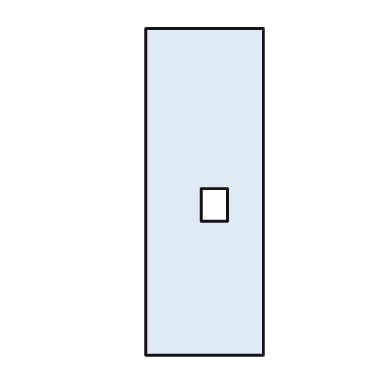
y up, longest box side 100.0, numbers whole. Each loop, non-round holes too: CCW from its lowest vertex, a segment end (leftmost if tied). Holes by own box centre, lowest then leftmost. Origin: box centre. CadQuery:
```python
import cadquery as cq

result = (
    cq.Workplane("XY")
    .moveTo(-18.0, -50.0)
    .lineTo(18.0, -50.0)
    .lineTo(18.0, 50.0)
    .lineTo(-18.0, 50.0)
    .close()
    .moveTo(-1.0, -9.0)
    .lineTo(7.0, -9.0)
    .lineTo(7.0, 1.0)
    .lineTo(-1.0, 1.0)
    .close()
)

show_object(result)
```